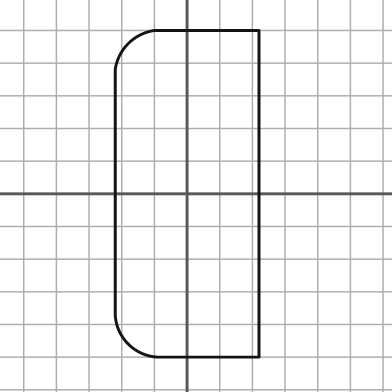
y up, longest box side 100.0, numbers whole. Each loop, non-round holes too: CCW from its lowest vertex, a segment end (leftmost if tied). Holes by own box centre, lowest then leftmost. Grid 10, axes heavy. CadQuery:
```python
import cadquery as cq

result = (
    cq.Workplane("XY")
    .moveTo(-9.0, -50.0)
    .lineTo(22.0, -50.0)
    .lineTo(22.0, 50.0)
    .lineTo(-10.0, 50.0)
    .threePointArc((-18.0, 46.0), (-22.0, 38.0))
    .lineTo(-22.0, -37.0)
    .threePointArc((-18.0, -46.0), (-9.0, -50.0))
    .close()
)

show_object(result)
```